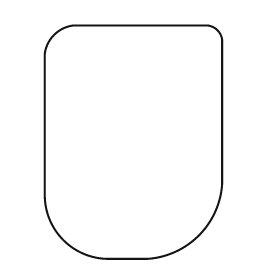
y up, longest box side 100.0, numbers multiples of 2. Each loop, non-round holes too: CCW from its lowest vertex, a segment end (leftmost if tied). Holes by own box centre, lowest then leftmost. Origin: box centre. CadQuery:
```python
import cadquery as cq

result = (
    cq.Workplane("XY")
    .moveTo(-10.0, -50.0)
    .lineTo(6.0, -50.0)
    .threePointArc((28.0, -40.0), (38.0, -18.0))
    .lineTo(38.0, 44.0)
    .threePointArc((36.0, 48.0), (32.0, 50.0))
    .lineTo(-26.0, 50.0)
    .threePointArc((-34.0, 46.0), (-38.0, 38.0))
    .lineTo(-38.0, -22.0)
    .threePointArc((-30.0, -42.0), (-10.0, -50.0))
    .close()
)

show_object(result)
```